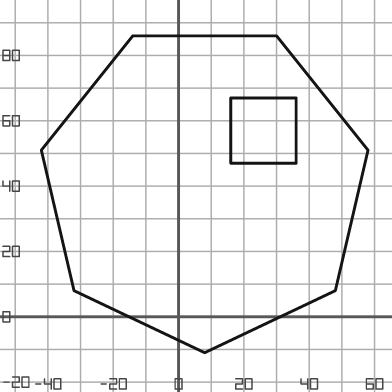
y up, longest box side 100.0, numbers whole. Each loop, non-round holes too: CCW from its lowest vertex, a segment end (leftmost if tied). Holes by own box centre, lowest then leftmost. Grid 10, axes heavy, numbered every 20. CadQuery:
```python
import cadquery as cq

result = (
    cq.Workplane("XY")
    .moveTo(8.0, -11.0)
    .lineTo(48.0, 8.0)
    .lineTo(58.0, 51.0)
    .lineTo(30.0, 86.0)
    .lineTo(-14.0, 86.0)
    .lineTo(-42.0, 51.0)
    .lineTo(-32.0, 8.0)
    .close()
    .moveTo(16.0, 47.0)
    .lineTo(36.0, 47.0)
    .lineTo(36.0, 67.0)
    .lineTo(16.0, 67.0)
    .close()
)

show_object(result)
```